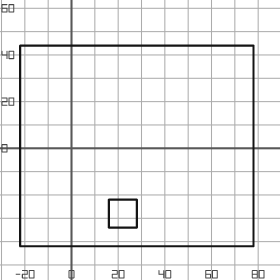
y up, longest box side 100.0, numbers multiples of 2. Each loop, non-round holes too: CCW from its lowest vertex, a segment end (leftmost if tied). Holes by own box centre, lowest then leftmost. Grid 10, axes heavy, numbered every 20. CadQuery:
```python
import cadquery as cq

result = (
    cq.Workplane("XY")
    .moveTo(-22.0, -42.0)
    .lineTo(78.0, -42.0)
    .lineTo(78.0, 44.0)
    .lineTo(-22.0, 44.0)
    .close()
    .moveTo(16.0, -34.0)
    .lineTo(28.0, -34.0)
    .lineTo(28.0, -22.0)
    .lineTo(16.0, -22.0)
    .close()
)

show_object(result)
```